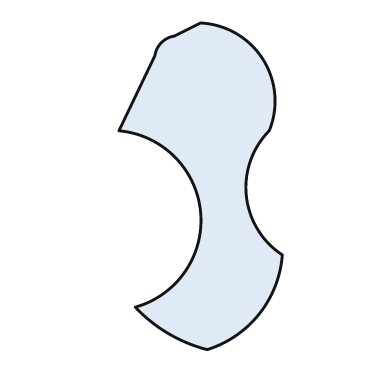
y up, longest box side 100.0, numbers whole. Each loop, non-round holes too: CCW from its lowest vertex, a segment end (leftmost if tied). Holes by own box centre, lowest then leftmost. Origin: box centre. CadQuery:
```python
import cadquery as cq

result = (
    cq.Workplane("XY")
    .moveTo(2.0, -50.0)
    .threePointArc((18.0, -39.0), (25.0, -21.0))
    .threePointArc((14.0, -3.0), (21.0, 17.0))
    .threePointArc((19.0, 39.0), (0.0, 50.0))
    .lineTo(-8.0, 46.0)
    .threePointArc((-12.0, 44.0), (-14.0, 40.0))
    .lineTo(-25.0, 17.0)
    .threePointArc((0.0, -8.0), (-20.0, -37.0))
    .threePointArc((-10.0, -45.0), (2.0, -50.0))
    .close()
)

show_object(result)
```